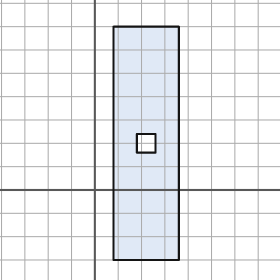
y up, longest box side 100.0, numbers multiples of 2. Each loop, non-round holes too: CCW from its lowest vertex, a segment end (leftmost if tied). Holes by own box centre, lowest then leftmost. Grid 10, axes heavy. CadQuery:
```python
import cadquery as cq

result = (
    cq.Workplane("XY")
    .moveTo(8.0, -30.0)
    .lineTo(36.0, -30.0)
    .lineTo(36.0, 70.0)
    .lineTo(8.0, 70.0)
    .close()
    .moveTo(18.0, 16.0)
    .lineTo(26.0, 16.0)
    .lineTo(26.0, 24.0)
    .lineTo(18.0, 24.0)
    .close()
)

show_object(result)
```